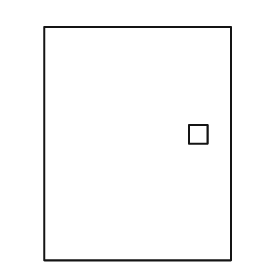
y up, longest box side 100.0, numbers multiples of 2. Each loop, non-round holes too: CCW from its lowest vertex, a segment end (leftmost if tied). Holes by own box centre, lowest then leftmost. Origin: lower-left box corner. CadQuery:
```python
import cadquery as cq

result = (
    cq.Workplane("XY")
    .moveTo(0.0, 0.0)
    .lineTo(80.0, 0.0)
    .lineTo(80.0, 100.0)
    .lineTo(0.0, 100.0)
    .close()
    .moveTo(62.0, 50.0)
    .lineTo(70.0, 50.0)
    .lineTo(70.0, 58.0)
    .lineTo(62.0, 58.0)
    .close()
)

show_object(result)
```